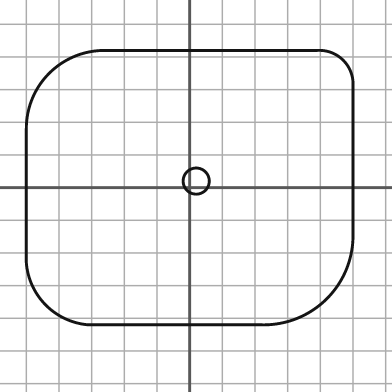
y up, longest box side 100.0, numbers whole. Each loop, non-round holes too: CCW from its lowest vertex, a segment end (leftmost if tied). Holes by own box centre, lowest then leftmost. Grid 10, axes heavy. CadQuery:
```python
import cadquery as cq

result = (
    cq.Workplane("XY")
    .moveTo(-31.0, -42.0)
    .lineTo(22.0, -42.0)
    .threePointArc((42.0, -34.0), (50.0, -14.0))
    .lineTo(50.0, 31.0)
    .threePointArc((47.0, 39.0), (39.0, 42.0))
    .lineTo(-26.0, 42.0)
    .threePointArc((-43.0, 35.0), (-50.0, 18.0))
    .lineTo(-50.0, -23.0)
    .threePointArc((-44.0, -36.0), (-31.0, -42.0))
    .close()
    .moveTo(2.0, 2.0)
    .circle(4.0)
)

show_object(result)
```